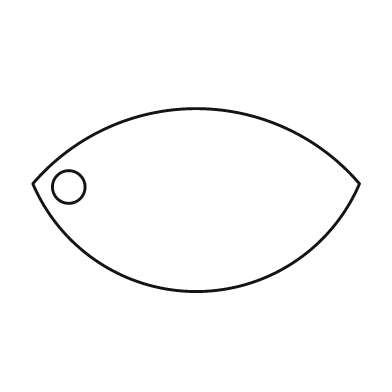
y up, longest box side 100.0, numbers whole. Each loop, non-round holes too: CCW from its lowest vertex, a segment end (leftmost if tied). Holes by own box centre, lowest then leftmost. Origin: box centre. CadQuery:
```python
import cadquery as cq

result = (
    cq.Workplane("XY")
    .moveTo(-50.0, 5.0)
    .threePointArc((0.0, -28.0), (50.0, 5.0))
    .threePointArc((0.0, 28.0), (-50.0, 5.0))
    .close()
    .moveTo(-39.0, 4.0)
    .circle(5.0)
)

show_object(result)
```